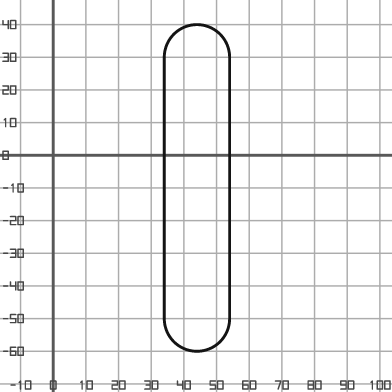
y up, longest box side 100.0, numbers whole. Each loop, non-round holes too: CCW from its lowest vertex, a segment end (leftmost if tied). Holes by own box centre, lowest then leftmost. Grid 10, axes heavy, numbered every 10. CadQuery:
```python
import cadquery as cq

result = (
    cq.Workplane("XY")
    .moveTo(34.0, -50.0)
    .threePointArc((44.0, -60.0), (54.0, -50.0))
    .lineTo(54.0, 30.0)
    .threePointArc((44.0, 40.0), (34.0, 30.0))
    .close()
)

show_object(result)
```